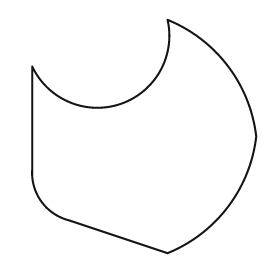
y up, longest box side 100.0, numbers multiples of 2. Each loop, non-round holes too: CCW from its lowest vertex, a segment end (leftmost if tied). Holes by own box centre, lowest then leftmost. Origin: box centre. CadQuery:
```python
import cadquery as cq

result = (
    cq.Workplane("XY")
    .moveTo(10.0, -50.0)
    .threePointArc((36.0, -30.0), (48.0, 0.0))
    .threePointArc((36.0, 30.0), (10.0, 50.0))
    .threePointArc((-10.0, 14.0), (-48.0, 30.0))
    .lineTo(-48.0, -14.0)
    .threePointArc((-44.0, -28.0), (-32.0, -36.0))
    .close()
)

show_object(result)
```